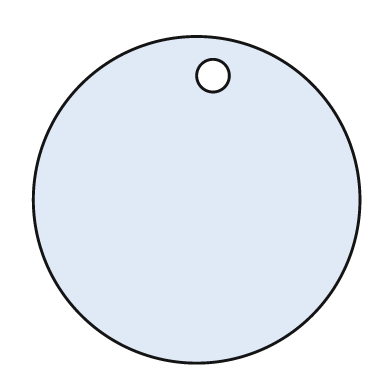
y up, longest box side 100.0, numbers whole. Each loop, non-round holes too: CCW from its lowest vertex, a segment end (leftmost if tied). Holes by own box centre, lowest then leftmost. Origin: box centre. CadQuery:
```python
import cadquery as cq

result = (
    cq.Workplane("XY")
    .moveTo(0.0, 0.0)
    .circle(50.0)
    .moveTo(5.0, 38.0)
    .circle(5.0)
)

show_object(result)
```